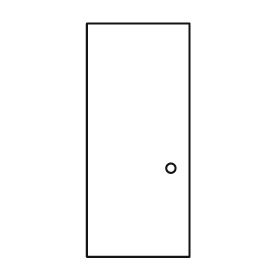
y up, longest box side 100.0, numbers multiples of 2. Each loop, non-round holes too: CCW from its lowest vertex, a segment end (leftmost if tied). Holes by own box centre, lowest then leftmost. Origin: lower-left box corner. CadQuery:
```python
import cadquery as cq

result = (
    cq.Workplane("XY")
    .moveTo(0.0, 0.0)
    .lineTo(44.0, 0.0)
    .lineTo(44.0, 100.0)
    .lineTo(0.0, 100.0)
    .close()
    .moveTo(36.0, 38.0)
    .circle(2.0)
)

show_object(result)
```